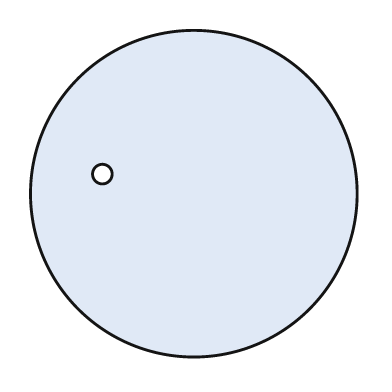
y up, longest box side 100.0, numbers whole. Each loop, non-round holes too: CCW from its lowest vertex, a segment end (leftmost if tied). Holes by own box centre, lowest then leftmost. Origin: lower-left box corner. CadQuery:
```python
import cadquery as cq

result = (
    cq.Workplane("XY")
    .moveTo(50.0, 50.0)
    .circle(50.0)
    .moveTo(22.0, 56.0)
    .circle(3.0)
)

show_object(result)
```